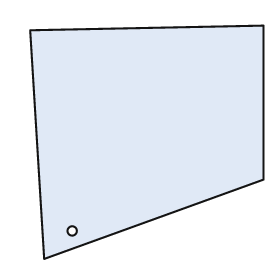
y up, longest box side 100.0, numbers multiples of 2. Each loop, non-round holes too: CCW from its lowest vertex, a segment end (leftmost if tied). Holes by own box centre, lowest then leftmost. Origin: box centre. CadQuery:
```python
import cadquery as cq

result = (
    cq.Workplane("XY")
    .moveTo(-44.0, -50.0)
    .lineTo(50.0, -16.0)
    .lineTo(50.0, 50.0)
    .lineTo(-50.0, 48.0)
    .close()
    .moveTo(-32.0, -38.0)
    .circle(2.0)
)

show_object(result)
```